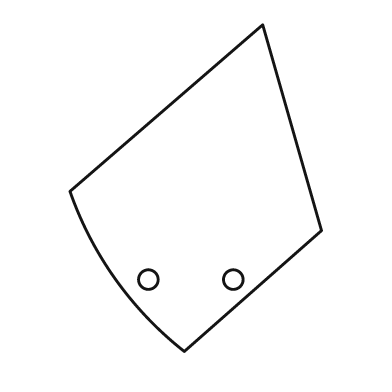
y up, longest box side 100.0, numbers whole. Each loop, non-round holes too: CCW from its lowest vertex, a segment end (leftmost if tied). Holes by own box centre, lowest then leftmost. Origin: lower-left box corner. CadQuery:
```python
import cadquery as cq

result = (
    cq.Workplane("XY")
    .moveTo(35.0, 0.0)
    .lineTo(77.0, 37.0)
    .lineTo(59.0, 100.0)
    .lineTo(0.0, 49.0)
    .threePointArc((14.0, 22.0), (35.0, 0.0))
    .close()
    .moveTo(24.0, 22.0)
    .circle(3.0)
    .moveTo(50.0, 22.0)
    .circle(3.0)
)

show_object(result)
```